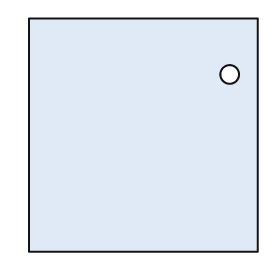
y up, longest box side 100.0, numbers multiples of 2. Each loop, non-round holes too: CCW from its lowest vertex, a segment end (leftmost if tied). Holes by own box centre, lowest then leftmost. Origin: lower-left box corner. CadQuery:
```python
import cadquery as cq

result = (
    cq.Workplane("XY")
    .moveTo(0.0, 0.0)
    .lineTo(98.0, 0.0)
    .lineTo(98.0, 100.0)
    .lineTo(0.0, 100.0)
    .close()
    .moveTo(86.0, 76.0)
    .circle(4.0)
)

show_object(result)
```